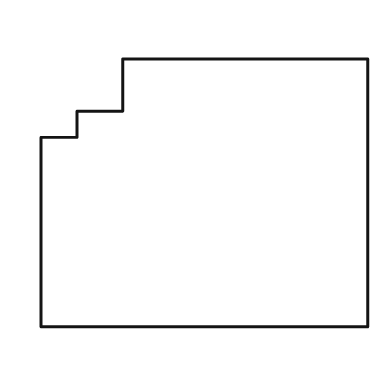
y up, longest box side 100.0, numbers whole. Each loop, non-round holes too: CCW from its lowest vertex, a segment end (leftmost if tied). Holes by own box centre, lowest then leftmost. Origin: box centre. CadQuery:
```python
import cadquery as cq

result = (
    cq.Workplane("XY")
    .moveTo(-50.0, -41.0)
    .lineTo(50.0, -41.0)
    .lineTo(50.0, 41.0)
    .lineTo(-25.0, 41.0)
    .lineTo(-25.0, 25.0)
    .lineTo(-39.0, 25.0)
    .lineTo(-39.0, 17.0)
    .lineTo(-50.0, 17.0)
    .close()
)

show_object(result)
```